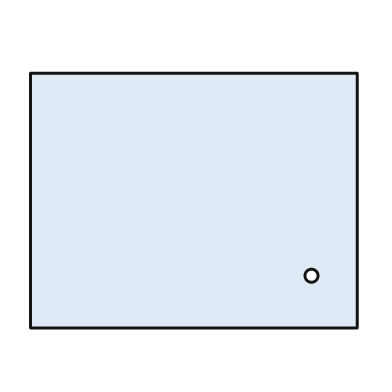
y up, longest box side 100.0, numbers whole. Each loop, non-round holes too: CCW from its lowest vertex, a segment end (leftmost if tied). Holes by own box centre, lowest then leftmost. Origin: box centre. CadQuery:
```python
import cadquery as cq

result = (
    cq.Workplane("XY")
    .moveTo(-50.0, -39.0)
    .lineTo(50.0, -39.0)
    .lineTo(50.0, 39.0)
    .lineTo(-50.0, 39.0)
    .close()
    .moveTo(36.0, -23.0)
    .circle(2.0)
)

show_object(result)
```